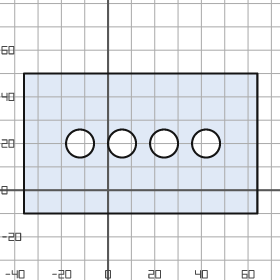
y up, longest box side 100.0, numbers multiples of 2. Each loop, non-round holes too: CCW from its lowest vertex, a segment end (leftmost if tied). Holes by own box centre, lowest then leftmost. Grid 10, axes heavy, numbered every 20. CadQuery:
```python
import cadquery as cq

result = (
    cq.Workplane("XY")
    .moveTo(-36.0, -10.0)
    .lineTo(64.0, -10.0)
    .lineTo(64.0, 50.0)
    .lineTo(-36.0, 50.0)
    .close()
    .moveTo(-12.0, 20.0)
    .circle(6.0)
    .moveTo(6.0, 20.0)
    .circle(6.0)
    .moveTo(24.0, 20.0)
    .circle(6.0)
    .moveTo(42.0, 20.0)
    .circle(6.0)
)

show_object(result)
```